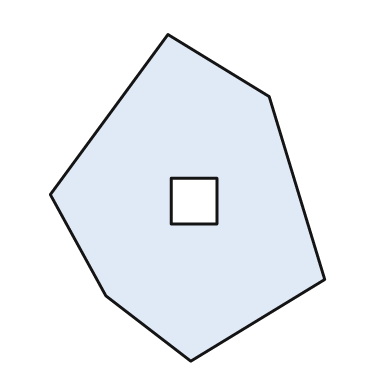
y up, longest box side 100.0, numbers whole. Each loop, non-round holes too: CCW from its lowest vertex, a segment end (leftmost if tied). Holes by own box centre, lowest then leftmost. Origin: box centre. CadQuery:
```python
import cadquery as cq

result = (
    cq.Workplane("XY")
    .moveTo(1.0, -50.0)
    .lineTo(42.0, -25.0)
    .lineTo(25.0, 31.0)
    .lineTo(-6.0, 50.0)
    .lineTo(-42.0, 1.0)
    .lineTo(-25.0, -30.0)
    .close()
    .moveTo(-5.0, -8.0)
    .lineTo(9.0, -8.0)
    .lineTo(9.0, 6.0)
    .lineTo(-5.0, 6.0)
    .close()
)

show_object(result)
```